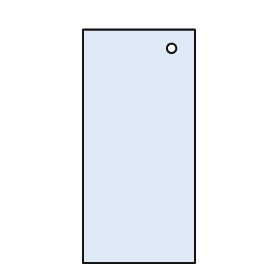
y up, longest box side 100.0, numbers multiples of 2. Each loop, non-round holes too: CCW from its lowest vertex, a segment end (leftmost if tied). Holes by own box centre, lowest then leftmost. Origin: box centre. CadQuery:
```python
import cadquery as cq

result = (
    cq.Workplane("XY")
    .moveTo(-24.0, -50.0)
    .lineTo(24.0, -50.0)
    .lineTo(24.0, 50.0)
    .lineTo(-24.0, 50.0)
    .close()
    .moveTo(14.0, 42.0)
    .circle(2.0)
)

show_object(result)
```